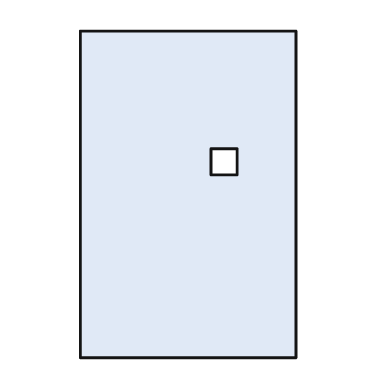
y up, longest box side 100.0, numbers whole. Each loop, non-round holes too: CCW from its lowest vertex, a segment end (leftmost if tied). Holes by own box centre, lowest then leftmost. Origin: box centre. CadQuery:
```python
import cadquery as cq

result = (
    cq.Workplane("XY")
    .moveTo(-33.0, -50.0)
    .lineTo(33.0, -50.0)
    .lineTo(33.0, 50.0)
    .lineTo(-33.0, 50.0)
    .close()
    .moveTo(7.0, 6.0)
    .lineTo(15.0, 6.0)
    .lineTo(15.0, 14.0)
    .lineTo(7.0, 14.0)
    .close()
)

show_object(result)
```